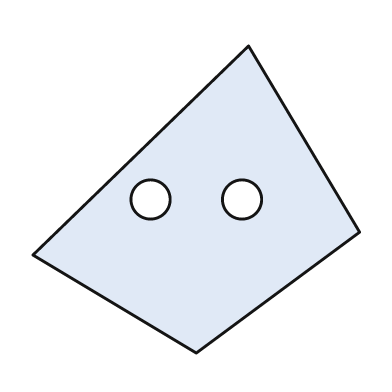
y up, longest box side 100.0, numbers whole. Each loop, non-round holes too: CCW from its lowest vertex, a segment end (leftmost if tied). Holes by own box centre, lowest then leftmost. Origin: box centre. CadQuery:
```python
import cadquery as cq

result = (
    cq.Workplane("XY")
    .moveTo(0.0, -47.0)
    .lineTo(50.0, -10.0)
    .lineTo(16.0, 47.0)
    .lineTo(-50.0, -17.0)
    .close()
    .moveTo(-14.0, 0.0)
    .circle(6.0)
    .moveTo(14.0, 0.0)
    .circle(6.0)
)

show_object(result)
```